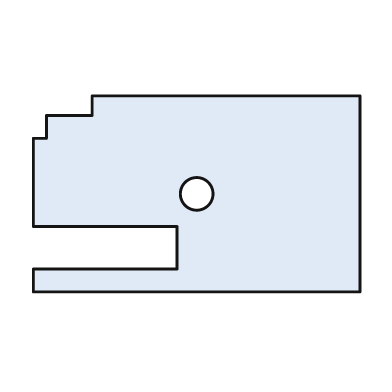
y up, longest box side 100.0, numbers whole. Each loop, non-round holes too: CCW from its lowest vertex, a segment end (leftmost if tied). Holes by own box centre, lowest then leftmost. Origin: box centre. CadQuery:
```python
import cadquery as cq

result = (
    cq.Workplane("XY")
    .moveTo(-50.0, -30.0)
    .lineTo(50.0, -30.0)
    .lineTo(50.0, 30.0)
    .lineTo(-32.0, 30.0)
    .lineTo(-32.0, 24.0)
    .lineTo(-46.0, 24.0)
    .lineTo(-46.0, 17.0)
    .lineTo(-50.0, 17.0)
    .lineTo(-50.0, -10.0)
    .lineTo(-6.0, -10.0)
    .lineTo(-6.0, -23.0)
    .lineTo(-50.0, -23.0)
    .close()
    .moveTo(0.0, 0.0)
    .circle(5.0)
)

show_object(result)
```